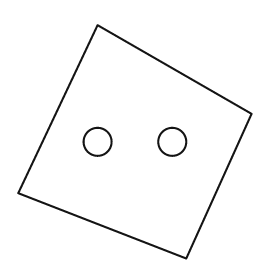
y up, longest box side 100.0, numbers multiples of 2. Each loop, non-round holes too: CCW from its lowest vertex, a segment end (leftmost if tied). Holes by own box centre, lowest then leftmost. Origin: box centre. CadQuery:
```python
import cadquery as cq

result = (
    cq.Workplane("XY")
    .moveTo(22.0, -50.0)
    .lineTo(50.0, 12.0)
    .lineTo(-16.0, 50.0)
    .lineTo(-50.0, -22.0)
    .close()
    .moveTo(-16.0, 0.0)
    .circle(6.0)
    .moveTo(16.0, 0.0)
    .circle(6.0)
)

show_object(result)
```